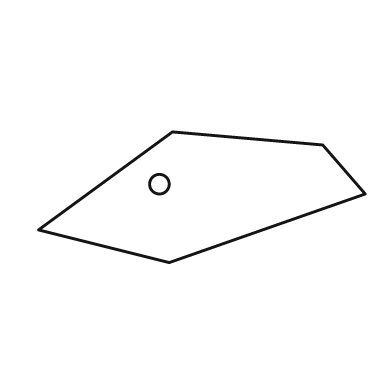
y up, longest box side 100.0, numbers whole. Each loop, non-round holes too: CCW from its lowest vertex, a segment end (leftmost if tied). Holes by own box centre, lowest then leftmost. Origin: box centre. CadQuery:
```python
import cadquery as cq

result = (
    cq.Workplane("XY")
    .moveTo(-10.0, -20.0)
    .lineTo(50.0, 1.0)
    .lineTo(37.0, 16.0)
    .lineTo(-9.0, 20.0)
    .lineTo(-50.0, -10.0)
    .close()
    .moveTo(-13.0, 4.0)
    .circle(3.0)
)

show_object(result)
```